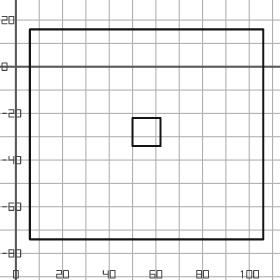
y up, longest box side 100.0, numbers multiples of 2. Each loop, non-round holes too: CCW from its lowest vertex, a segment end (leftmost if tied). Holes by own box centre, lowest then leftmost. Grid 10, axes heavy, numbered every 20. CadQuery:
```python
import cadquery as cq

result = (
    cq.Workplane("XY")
    .moveTo(6.0, -74.0)
    .lineTo(106.0, -74.0)
    .lineTo(106.0, 16.0)
    .lineTo(6.0, 16.0)
    .close()
    .moveTo(50.0, -34.0)
    .lineTo(62.0, -34.0)
    .lineTo(62.0, -22.0)
    .lineTo(50.0, -22.0)
    .close()
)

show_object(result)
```